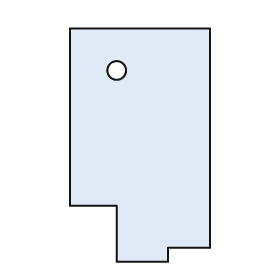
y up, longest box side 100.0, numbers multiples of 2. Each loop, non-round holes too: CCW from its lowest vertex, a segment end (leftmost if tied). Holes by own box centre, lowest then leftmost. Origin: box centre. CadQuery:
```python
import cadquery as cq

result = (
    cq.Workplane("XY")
    .moveTo(-10.0, -50.0)
    .lineTo(12.0, -50.0)
    .lineTo(12.0, -44.0)
    .lineTo(30.0, -44.0)
    .lineTo(30.0, 50.0)
    .lineTo(-30.0, 50.0)
    .lineTo(-30.0, -26.0)
    .lineTo(-10.0, -26.0)
    .close()
    .moveTo(-10.0, 32.0)
    .circle(4.0)
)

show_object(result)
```